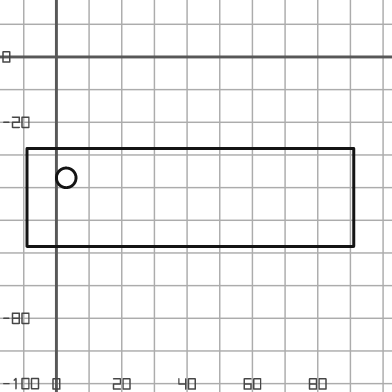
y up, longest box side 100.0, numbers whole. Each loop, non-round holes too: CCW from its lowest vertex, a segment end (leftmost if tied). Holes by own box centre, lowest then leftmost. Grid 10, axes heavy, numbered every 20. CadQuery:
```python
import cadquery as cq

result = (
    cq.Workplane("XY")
    .moveTo(-9.0, -58.0)
    .lineTo(91.0, -58.0)
    .lineTo(91.0, -28.0)
    .lineTo(-9.0, -28.0)
    .close()
    .moveTo(3.0, -37.0)
    .circle(3.0)
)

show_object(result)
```